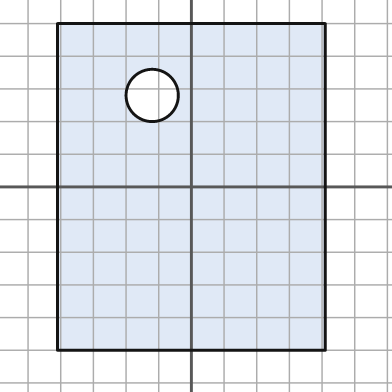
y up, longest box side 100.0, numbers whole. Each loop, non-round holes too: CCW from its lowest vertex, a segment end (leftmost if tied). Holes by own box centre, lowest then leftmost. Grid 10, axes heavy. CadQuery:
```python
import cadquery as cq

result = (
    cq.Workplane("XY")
    .moveTo(-41.0, -50.0)
    .lineTo(41.0, -50.0)
    .lineTo(41.0, 50.0)
    .lineTo(-41.0, 50.0)
    .close()
    .moveTo(-12.0, 28.0)
    .circle(8.0)
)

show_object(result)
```